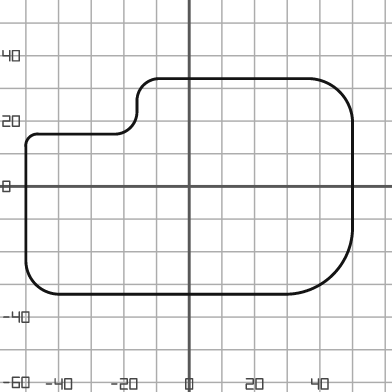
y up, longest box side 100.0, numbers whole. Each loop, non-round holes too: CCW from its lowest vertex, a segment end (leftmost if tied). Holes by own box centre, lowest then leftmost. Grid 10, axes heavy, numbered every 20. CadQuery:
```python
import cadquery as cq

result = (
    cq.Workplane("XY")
    .moveTo(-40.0, -33.0)
    .lineTo(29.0, -33.0)
    .threePointArc((44.0, -27.0), (50.0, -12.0))
    .lineTo(50.0, 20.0)
    .threePointArc((46.0, 29.0), (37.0, 33.0))
    .lineTo(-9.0, 33.0)
    .threePointArc((-14.0, 31.0), (-16.0, 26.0))
    .lineTo(-16.0, 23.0)
    .threePointArc((-18.0, 18.0), (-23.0, 16.0))
    .lineTo(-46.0, 16.0)
    .threePointArc((-49.0, 15.0), (-50.0, 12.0))
    .lineTo(-50.0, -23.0)
    .threePointArc((-47.0, -30.0), (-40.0, -33.0))
    .close()
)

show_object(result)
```